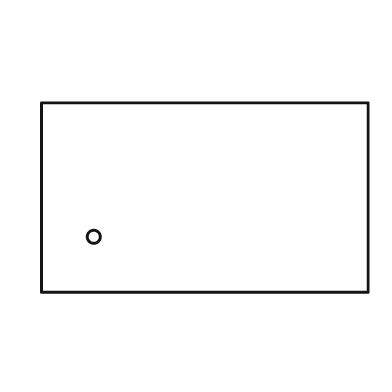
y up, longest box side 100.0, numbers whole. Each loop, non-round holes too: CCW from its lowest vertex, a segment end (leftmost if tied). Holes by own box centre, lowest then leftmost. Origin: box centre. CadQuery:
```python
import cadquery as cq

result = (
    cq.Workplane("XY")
    .moveTo(-50.0, -29.0)
    .lineTo(50.0, -29.0)
    .lineTo(50.0, 29.0)
    .lineTo(-50.0, 29.0)
    .close()
    .moveTo(-34.0, -12.0)
    .circle(2.0)
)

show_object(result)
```